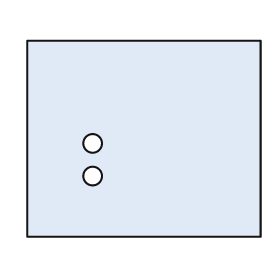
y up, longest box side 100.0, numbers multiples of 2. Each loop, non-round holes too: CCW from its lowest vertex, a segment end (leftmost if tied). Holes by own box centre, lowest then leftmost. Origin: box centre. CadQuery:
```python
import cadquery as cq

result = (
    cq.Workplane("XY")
    .moveTo(-50.0, -42.0)
    .lineTo(50.0, -42.0)
    .lineTo(50.0, 42.0)
    .lineTo(-50.0, 42.0)
    .close()
    .moveTo(-22.0, -16.0)
    .circle(4.0)
    .moveTo(-22.0, -2.0)
    .circle(4.0)
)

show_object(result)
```